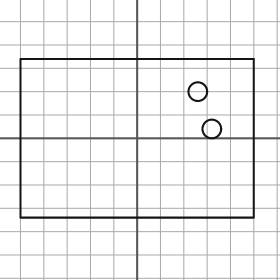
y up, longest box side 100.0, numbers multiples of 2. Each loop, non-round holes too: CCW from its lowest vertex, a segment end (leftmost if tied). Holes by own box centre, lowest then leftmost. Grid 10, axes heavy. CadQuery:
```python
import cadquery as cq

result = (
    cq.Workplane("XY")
    .moveTo(-50.0, -34.0)
    .lineTo(50.0, -34.0)
    .lineTo(50.0, 34.0)
    .lineTo(-50.0, 34.0)
    .close()
    .moveTo(32.0, 4.0)
    .circle(4.0)
    .moveTo(26.0, 20.0)
    .circle(4.0)
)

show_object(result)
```